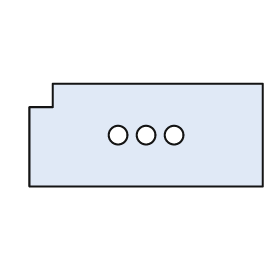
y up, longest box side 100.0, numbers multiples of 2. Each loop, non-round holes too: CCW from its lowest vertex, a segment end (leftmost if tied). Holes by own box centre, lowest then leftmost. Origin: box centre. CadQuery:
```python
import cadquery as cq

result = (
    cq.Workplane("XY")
    .moveTo(-50.0, -22.0)
    .lineTo(50.0, -22.0)
    .lineTo(50.0, 22.0)
    .lineTo(-40.0, 22.0)
    .lineTo(-40.0, 12.0)
    .lineTo(-50.0, 12.0)
    .close()
    .moveTo(-12.0, 0.0)
    .circle(4.0)
    .moveTo(0.0, 0.0)
    .circle(4.0)
    .moveTo(12.0, 0.0)
    .circle(4.0)
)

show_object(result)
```